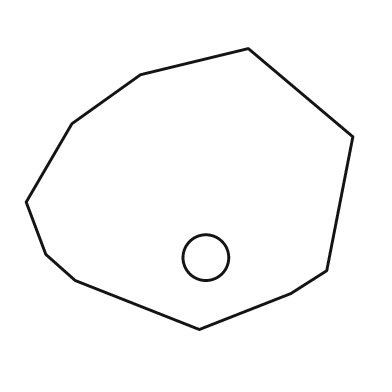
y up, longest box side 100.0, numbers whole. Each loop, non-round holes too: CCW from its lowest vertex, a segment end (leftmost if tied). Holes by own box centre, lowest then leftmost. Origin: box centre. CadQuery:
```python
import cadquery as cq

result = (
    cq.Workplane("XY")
    .moveTo(3.0, -43.0)
    .lineTo(31.0, -32.0)
    .lineTo(42.0, -25.0)
    .lineTo(50.0, 16.0)
    .lineTo(18.0, 43.0)
    .lineTo(-15.0, 35.0)
    .lineTo(-36.0, 20.0)
    .lineTo(-50.0, -4.0)
    .lineTo(-44.0, -20.0)
    .lineTo(-35.0, -28.0)
    .close()
    .moveTo(5.0, -21.0)
    .circle(7.0)
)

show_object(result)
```